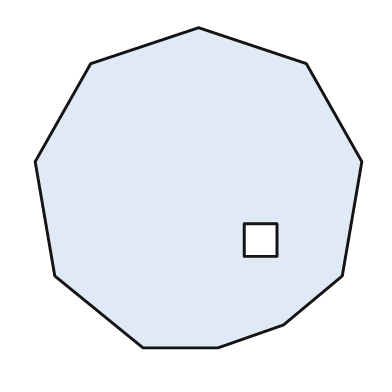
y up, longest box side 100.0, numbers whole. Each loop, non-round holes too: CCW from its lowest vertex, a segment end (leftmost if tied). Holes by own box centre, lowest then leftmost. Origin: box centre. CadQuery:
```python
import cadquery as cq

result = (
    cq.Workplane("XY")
    .moveTo(-17.0, -49.0)
    .lineTo(6.0, -49.0)
    .lineTo(26.0, -42.0)
    .lineTo(44.0, -27.0)
    .lineTo(50.0, 8.0)
    .lineTo(33.0, 38.0)
    .lineTo(0.0, 49.0)
    .lineTo(-33.0, 38.0)
    .lineTo(-50.0, 8.0)
    .lineTo(-44.0, -27.0)
    .close()
    .moveTo(14.0, -21.0)
    .lineTo(24.0, -21.0)
    .lineTo(24.0, -11.0)
    .lineTo(14.0, -11.0)
    .close()
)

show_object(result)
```